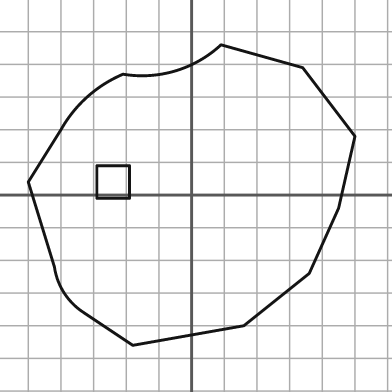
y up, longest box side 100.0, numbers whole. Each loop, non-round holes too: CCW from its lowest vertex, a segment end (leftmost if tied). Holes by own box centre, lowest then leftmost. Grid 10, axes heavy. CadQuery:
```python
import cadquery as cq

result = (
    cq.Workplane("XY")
    .moveTo(-18.0, -46.0)
    .lineTo(16.0, -40.0)
    .lineTo(36.0, -24.0)
    .lineTo(45.0, -4.0)
    .lineTo(50.0, 18.0)
    .lineTo(34.0, 39.0)
    .lineTo(9.0, 46.0)
    .threePointArc((-5.0, 38.0), (-21.0, 37.0))
    .threePointArc((-32.0, 30.0), (-40.0, 20.0))
    .lineTo(-50.0, 4.0)
    .lineTo(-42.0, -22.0)
    .threePointArc((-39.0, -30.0), (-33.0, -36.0))
    .close()
    .moveTo(-29.0, -1.0)
    .lineTo(-19.0, -1.0)
    .lineTo(-19.0, 9.0)
    .lineTo(-29.0, 9.0)
    .close()
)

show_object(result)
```